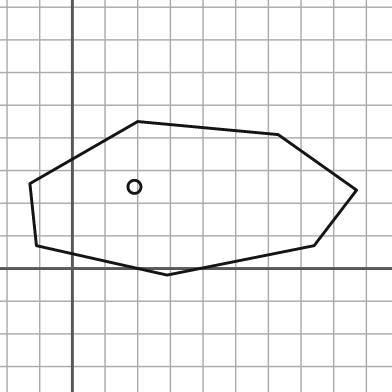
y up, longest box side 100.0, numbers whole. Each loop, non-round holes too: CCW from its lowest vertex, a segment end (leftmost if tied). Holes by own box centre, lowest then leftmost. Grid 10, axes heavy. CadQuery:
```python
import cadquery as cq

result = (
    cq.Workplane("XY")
    .moveTo(29.0, -2.0)
    .lineTo(74.0, 7.0)
    .lineTo(87.0, 24.0)
    .lineTo(63.0, 41.0)
    .lineTo(20.0, 45.0)
    .lineTo(-13.0, 26.0)
    .lineTo(-11.0, 7.0)
    .close()
    .moveTo(19.0, 25.0)
    .circle(2.0)
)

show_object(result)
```